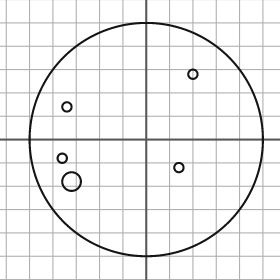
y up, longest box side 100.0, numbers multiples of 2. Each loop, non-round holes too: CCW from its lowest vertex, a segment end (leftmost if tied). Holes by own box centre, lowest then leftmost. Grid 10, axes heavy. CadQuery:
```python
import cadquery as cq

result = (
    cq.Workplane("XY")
    .moveTo(0.0, 0.0)
    .circle(50.0)
    .moveTo(-32.0, -18.0)
    .circle(4.0)
    .moveTo(14.0, -12.0)
    .circle(2.0)
    .moveTo(-36.0, -8.0)
    .circle(2.0)
    .moveTo(-34.0, 14.0)
    .circle(2.0)
    .moveTo(20.0, 28.0)
    .circle(2.0)
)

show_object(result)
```